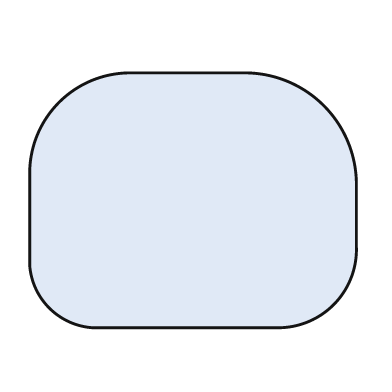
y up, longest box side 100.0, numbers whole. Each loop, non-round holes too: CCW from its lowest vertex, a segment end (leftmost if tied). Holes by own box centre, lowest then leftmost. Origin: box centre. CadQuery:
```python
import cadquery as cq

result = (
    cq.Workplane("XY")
    .moveTo(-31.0, -39.0)
    .lineTo(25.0, -39.0)
    .threePointArc((43.0, -32.0), (50.0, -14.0))
    .lineTo(50.0, 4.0)
    .threePointArc((40.0, 29.0), (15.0, 39.0))
    .lineTo(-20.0, 39.0)
    .threePointArc((-41.0, 30.0), (-50.0, 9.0))
    .lineTo(-50.0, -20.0)
    .threePointArc((-44.0, -33.0), (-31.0, -39.0))
    .close()
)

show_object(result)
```